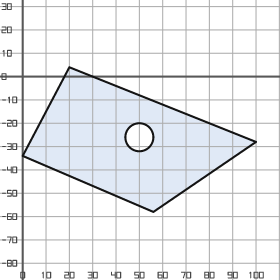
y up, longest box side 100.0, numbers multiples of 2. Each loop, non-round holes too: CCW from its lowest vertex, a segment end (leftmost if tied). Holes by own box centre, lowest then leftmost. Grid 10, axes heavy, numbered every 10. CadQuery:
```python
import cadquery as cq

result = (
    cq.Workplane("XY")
    .moveTo(56.0, -58.0)
    .lineTo(100.0, -28.0)
    .lineTo(20.0, 4.0)
    .lineTo(0.0, -34.0)
    .close()
    .moveTo(50.0, -26.0)
    .circle(6.0)
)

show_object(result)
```